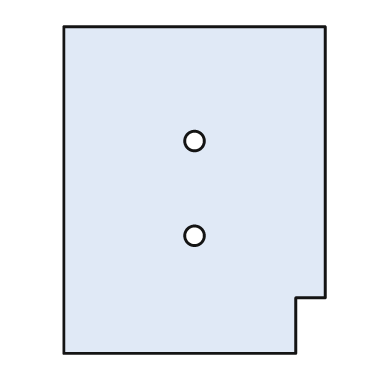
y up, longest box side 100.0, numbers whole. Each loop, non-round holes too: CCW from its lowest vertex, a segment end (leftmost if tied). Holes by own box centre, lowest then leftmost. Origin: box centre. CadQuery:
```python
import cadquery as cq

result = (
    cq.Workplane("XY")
    .moveTo(-40.0, -50.0)
    .lineTo(31.0, -50.0)
    .lineTo(31.0, -33.0)
    .lineTo(40.0, -33.0)
    .lineTo(40.0, 50.0)
    .lineTo(-40.0, 50.0)
    .close()
    .moveTo(0.0, -14.0)
    .circle(3.0)
    .moveTo(0.0, 15.0)
    .circle(3.0)
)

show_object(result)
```